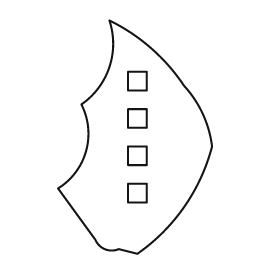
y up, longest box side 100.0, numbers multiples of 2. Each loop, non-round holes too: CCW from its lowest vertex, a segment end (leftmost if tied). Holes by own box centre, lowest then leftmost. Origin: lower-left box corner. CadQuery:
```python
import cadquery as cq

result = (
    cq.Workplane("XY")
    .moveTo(34.0, 0.0)
    .threePointArc((54.0, 20.0), (66.0, 46.0))
    .threePointArc((62.0, 60.0), (54.0, 72.0))
    .threePointArc((40.0, 88.0), (22.0, 100.0))
    .threePointArc((22.0, 80.0), (10.0, 64.0))
    .threePointArc((12.0, 44.0), (0.0, 28.0))
    .lineTo(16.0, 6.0)
    .threePointArc((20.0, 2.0), (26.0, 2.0))
    .close()
    .moveTo(30.0, 22.0)
    .lineTo(38.0, 22.0)
    .lineTo(38.0, 30.0)
    .lineTo(30.0, 30.0)
    .close()
    .moveTo(30.0, 38.0)
    .lineTo(38.0, 38.0)
    .lineTo(38.0, 46.0)
    .lineTo(30.0, 46.0)
    .close()
    .moveTo(30.0, 54.0)
    .lineTo(38.0, 54.0)
    .lineTo(38.0, 62.0)
    .lineTo(30.0, 62.0)
    .close()
    .moveTo(30.0, 70.0)
    .lineTo(38.0, 70.0)
    .lineTo(38.0, 78.0)
    .lineTo(30.0, 78.0)
    .close()
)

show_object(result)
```